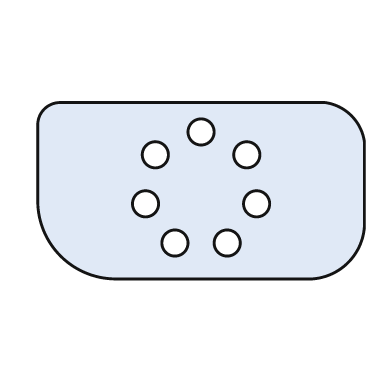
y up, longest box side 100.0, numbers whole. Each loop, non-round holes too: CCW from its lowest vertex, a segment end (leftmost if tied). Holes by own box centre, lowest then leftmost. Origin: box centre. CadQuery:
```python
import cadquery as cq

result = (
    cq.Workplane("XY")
    .moveTo(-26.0, -27.0)
    .lineTo(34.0, -27.0)
    .threePointArc((45.0, -22.0), (50.0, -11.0))
    .lineTo(50.0, 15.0)
    .threePointArc((46.0, 23.0), (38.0, 27.0))
    .lineTo(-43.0, 27.0)
    .threePointArc((-48.0, 25.0), (-50.0, 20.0))
    .lineTo(-50.0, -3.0)
    .threePointArc((-43.0, -20.0), (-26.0, -27.0))
    .close()
    .moveTo(-8.0, -16.0)
    .circle(4.0)
    .moveTo(8.0, -16.0)
    .circle(4.0)
    .moveTo(-17.0, -4.0)
    .circle(4.0)
    .moveTo(17.0, -4.0)
    .circle(4.0)
    .moveTo(-14.0, 11.0)
    .circle(4.0)
    .moveTo(14.0, 11.0)
    .circle(4.0)
    .moveTo(0.0, 18.0)
    .circle(4.0)
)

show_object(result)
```